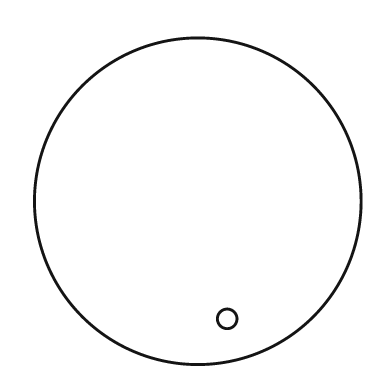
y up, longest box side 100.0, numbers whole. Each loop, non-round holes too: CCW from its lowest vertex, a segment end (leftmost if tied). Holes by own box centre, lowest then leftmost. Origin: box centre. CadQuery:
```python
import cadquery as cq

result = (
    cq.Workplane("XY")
    .moveTo(0.0, 0.0)
    .circle(50.0)
    .moveTo(9.0, -36.0)
    .circle(3.0)
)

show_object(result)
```